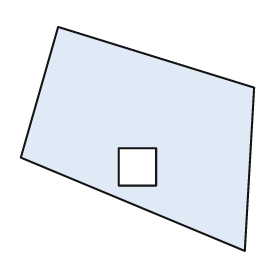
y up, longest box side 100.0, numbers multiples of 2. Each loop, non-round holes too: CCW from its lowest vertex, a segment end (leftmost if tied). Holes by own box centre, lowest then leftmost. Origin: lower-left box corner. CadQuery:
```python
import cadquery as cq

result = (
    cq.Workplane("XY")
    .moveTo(96.0, 0.0)
    .lineTo(100.0, 70.0)
    .lineTo(16.0, 96.0)
    .lineTo(0.0, 40.0)
    .close()
    .moveTo(42.0, 28.0)
    .lineTo(58.0, 28.0)
    .lineTo(58.0, 44.0)
    .lineTo(42.0, 44.0)
    .close()
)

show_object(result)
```